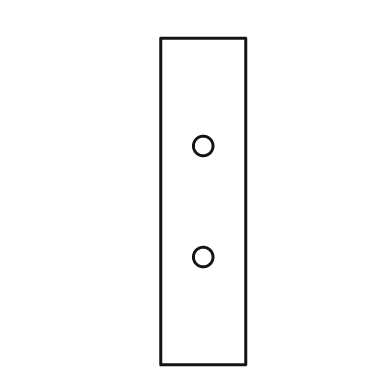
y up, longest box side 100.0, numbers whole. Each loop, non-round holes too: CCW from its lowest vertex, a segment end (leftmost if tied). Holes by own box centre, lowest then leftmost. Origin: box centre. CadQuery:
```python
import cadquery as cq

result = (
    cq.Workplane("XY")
    .moveTo(-13.0, -50.0)
    .lineTo(13.0, -50.0)
    .lineTo(13.0, 50.0)
    .lineTo(-13.0, 50.0)
    .close()
    .moveTo(0.0, -17.0)
    .circle(3.0)
    .moveTo(0.0, 17.0)
    .circle(3.0)
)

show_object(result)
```